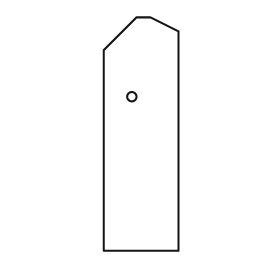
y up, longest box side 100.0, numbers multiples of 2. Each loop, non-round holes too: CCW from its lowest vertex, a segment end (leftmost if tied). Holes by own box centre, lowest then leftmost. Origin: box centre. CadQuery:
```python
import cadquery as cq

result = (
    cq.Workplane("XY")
    .moveTo(-16.0, -50.0)
    .lineTo(16.0, -50.0)
    .lineTo(16.0, 44.0)
    .lineTo(4.0, 50.0)
    .lineTo(-2.0, 50.0)
    .lineTo(-16.0, 36.0)
    .close()
    .moveTo(-4.0, 16.0)
    .circle(2.0)
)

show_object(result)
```